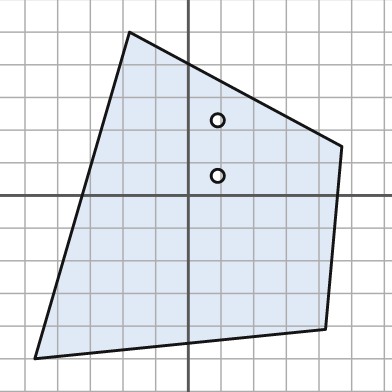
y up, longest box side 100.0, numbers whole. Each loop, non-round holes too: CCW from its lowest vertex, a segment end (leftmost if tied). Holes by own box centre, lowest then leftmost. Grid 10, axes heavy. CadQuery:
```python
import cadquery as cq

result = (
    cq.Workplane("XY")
    .moveTo(-47.0, -50.0)
    .lineTo(42.0, -41.0)
    .lineTo(47.0, 15.0)
    .lineTo(-18.0, 50.0)
    .close()
    .moveTo(9.0, 6.0)
    .circle(2.0)
    .moveTo(9.0, 23.0)
    .circle(2.0)
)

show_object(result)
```